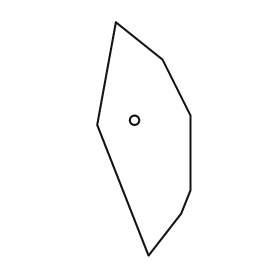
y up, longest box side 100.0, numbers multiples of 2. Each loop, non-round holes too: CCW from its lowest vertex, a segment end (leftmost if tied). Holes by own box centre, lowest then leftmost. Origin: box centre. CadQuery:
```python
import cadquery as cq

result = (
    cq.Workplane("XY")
    .moveTo(2.0, -50.0)
    .lineTo(16.0, -32.0)
    .lineTo(20.0, -22.0)
    .lineTo(20.0, 10.0)
    .lineTo(8.0, 34.0)
    .lineTo(-12.0, 50.0)
    .lineTo(-20.0, 6.0)
    .close()
    .moveTo(-4.0, 8.0)
    .circle(2.0)
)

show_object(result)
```